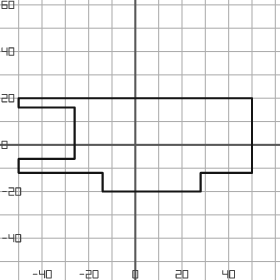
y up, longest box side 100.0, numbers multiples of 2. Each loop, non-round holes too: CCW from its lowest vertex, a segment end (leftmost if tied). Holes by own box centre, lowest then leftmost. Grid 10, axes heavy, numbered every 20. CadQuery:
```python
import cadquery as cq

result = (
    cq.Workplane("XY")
    .moveTo(-14.0, -20.0)
    .lineTo(28.0, -20.0)
    .lineTo(28.0, -12.0)
    .lineTo(50.0, -12.0)
    .lineTo(50.0, 20.0)
    .lineTo(-50.0, 20.0)
    .lineTo(-50.0, 16.0)
    .lineTo(-26.0, 16.0)
    .lineTo(-26.0, -6.0)
    .lineTo(-50.0, -6.0)
    .lineTo(-50.0, -12.0)
    .lineTo(-14.0, -12.0)
    .close()
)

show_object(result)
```